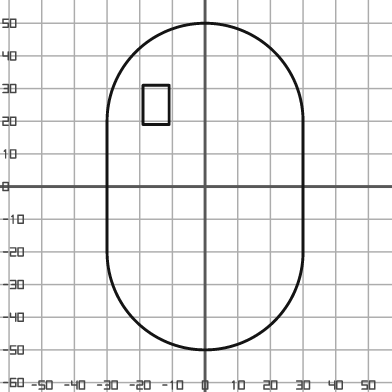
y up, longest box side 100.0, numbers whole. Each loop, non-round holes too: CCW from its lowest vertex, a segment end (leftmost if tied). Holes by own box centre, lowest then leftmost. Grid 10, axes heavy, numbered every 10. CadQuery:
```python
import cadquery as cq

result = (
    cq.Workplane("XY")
    .moveTo(-30.0, -20.0)
    .threePointArc((0.0, -50.0), (30.0, -20.0))
    .lineTo(30.0, 20.0)
    .threePointArc((0.0, 50.0), (-30.0, 20.0))
    .close()
    .moveTo(-19.0, 19.0)
    .lineTo(-11.0, 19.0)
    .lineTo(-11.0, 31.0)
    .lineTo(-19.0, 31.0)
    .close()
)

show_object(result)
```